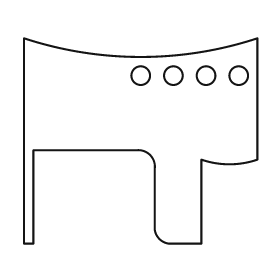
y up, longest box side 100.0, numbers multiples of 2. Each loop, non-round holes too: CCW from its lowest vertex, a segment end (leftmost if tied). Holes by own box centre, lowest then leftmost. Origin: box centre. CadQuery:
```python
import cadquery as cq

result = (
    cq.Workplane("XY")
    .moveTo(-50.0, -44.0)
    .lineTo(-46.0, -44.0)
    .lineTo(-46.0, -4.0)
    .lineTo(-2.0, -4.0)
    .threePointArc((4.0, -6.0), (6.0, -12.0))
    .lineTo(6.0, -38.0)
    .threePointArc((8.0, -42.0), (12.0, -44.0))
    .lineTo(26.0, -44.0)
    .lineTo(26.0, -8.0)
    .threePointArc((38.0, -10.0), (50.0, -8.0))
    .lineTo(50.0, 44.0)
    .threePointArc((0.0, 36.0), (-50.0, 44.0))
    .close()
    .moveTo(0.0, 28.0)
    .circle(4.0)
    .moveTo(14.0, 28.0)
    .circle(4.0)
    .moveTo(28.0, 28.0)
    .circle(4.0)
    .moveTo(42.0, 28.0)
    .circle(4.0)
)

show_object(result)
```